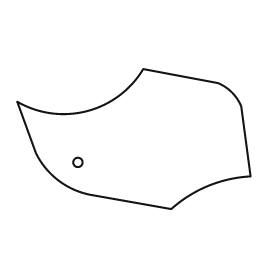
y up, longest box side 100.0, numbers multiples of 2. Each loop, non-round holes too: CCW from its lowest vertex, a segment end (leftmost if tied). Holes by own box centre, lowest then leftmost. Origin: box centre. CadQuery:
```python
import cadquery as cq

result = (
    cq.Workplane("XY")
    .moveTo(16.0, -30.0)
    .threePointArc((32.0, -20.0), (50.0, -16.0))
    .lineTo(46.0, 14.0)
    .threePointArc((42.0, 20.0), (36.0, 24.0))
    .lineTo(4.0, 30.0)
    .threePointArc((-20.0, 12.0), (-50.0, 16.0))
    .lineTo(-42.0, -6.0)
    .threePointArc((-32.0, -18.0), (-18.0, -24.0))
    .close()
    .moveTo(-24.0, -10.0)
    .circle(2.0)
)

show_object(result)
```